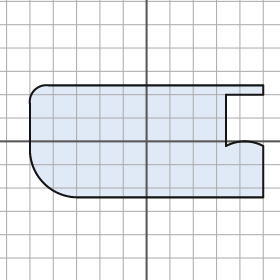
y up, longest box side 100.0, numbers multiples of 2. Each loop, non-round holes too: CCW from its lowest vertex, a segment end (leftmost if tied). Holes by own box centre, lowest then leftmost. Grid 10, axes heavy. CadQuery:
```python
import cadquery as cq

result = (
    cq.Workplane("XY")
    .moveTo(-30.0, -24.0)
    .lineTo(50.0, -24.0)
    .lineTo(50.0, -2.0)
    .threePointArc((42.0, 0.0), (34.0, -2.0))
    .lineTo(34.0, 20.0)
    .lineTo(50.0, 20.0)
    .lineTo(50.0, 24.0)
    .lineTo(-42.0, 24.0)
    .threePointArc((-48.0, 22.0), (-50.0, 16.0))
    .lineTo(-50.0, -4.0)
    .threePointArc((-44.0, -18.0), (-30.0, -24.0))
    .close()
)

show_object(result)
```